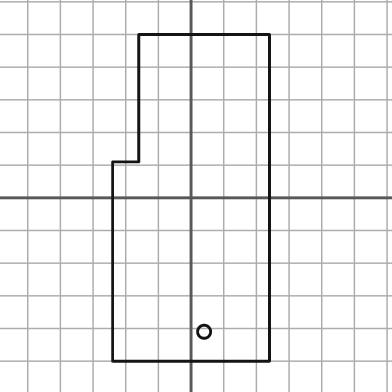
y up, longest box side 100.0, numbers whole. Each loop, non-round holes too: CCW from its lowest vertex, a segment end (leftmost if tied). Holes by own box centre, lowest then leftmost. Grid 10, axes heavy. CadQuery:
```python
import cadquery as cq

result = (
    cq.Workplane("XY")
    .moveTo(-24.0, -50.0)
    .lineTo(24.0, -50.0)
    .lineTo(24.0, 50.0)
    .lineTo(-16.0, 50.0)
    .lineTo(-16.0, 11.0)
    .lineTo(-24.0, 11.0)
    .close()
    .moveTo(4.0, -41.0)
    .circle(2.0)
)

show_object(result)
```